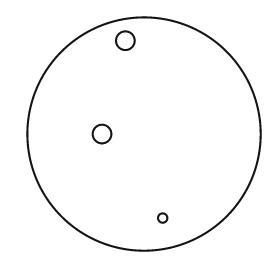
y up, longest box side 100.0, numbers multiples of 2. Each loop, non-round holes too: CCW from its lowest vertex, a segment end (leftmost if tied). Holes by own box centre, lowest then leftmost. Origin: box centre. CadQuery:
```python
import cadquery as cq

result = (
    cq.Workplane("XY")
    .moveTo(0.0, 0.0)
    .circle(50.0)
    .moveTo(8.0, -36.0)
    .circle(2.0)
    .moveTo(-18.0, 0.0)
    .circle(4.0)
    .moveTo(-8.0, 40.0)
    .circle(4.0)
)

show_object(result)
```